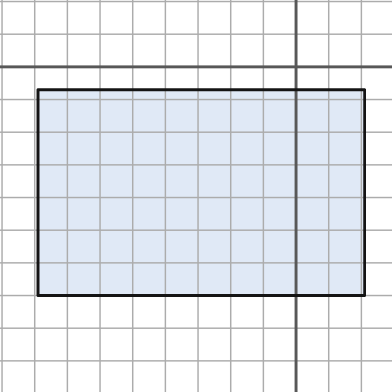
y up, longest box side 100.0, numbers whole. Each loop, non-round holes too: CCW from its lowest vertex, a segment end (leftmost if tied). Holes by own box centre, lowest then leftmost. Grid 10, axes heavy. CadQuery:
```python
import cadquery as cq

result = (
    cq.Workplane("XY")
    .moveTo(-79.0, -70.0)
    .lineTo(21.0, -70.0)
    .lineTo(21.0, -7.0)
    .lineTo(-79.0, -7.0)
    .close()
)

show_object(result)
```